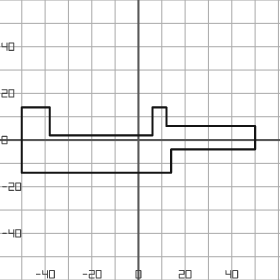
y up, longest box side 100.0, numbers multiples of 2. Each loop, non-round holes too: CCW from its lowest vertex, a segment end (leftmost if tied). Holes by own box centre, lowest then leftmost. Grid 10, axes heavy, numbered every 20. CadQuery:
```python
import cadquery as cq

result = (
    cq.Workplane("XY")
    .moveTo(-50.0, -14.0)
    .lineTo(14.0, -14.0)
    .lineTo(14.0, -4.0)
    .lineTo(50.0, -4.0)
    .lineTo(50.0, 6.0)
    .lineTo(12.0, 6.0)
    .lineTo(12.0, 14.0)
    .lineTo(6.0, 14.0)
    .lineTo(6.0, 2.0)
    .lineTo(-38.0, 2.0)
    .lineTo(-38.0, 14.0)
    .lineTo(-50.0, 14.0)
    .close()
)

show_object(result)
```